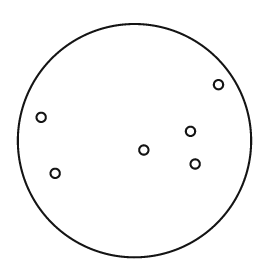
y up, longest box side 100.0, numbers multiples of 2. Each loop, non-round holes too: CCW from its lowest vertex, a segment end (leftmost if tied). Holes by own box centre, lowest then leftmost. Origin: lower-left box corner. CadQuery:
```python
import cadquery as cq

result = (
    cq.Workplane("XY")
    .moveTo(50.0, 50.0)
    .circle(50.0)
    .moveTo(16.0, 36.0)
    .circle(2.0)
    .moveTo(76.0, 40.0)
    .circle(2.0)
    .moveTo(54.0, 46.0)
    .circle(2.0)
    .moveTo(74.0, 54.0)
    .circle(2.0)
    .moveTo(10.0, 60.0)
    .circle(2.0)
    .moveTo(86.0, 74.0)
    .circle(2.0)
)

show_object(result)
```